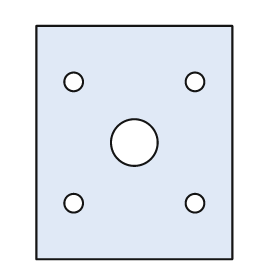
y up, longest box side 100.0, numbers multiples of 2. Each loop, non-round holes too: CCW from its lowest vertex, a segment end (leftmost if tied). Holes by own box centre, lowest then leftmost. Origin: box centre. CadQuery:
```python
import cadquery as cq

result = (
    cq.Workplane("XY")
    .moveTo(-42.0, -50.0)
    .lineTo(42.0, -50.0)
    .lineTo(42.0, 50.0)
    .lineTo(-42.0, 50.0)
    .close()
    .moveTo(-26.0, -26.0)
    .circle(4.0)
    .moveTo(26.0, -26.0)
    .circle(4.0)
    .moveTo(0.0, 0.0)
    .circle(10.0)
    .moveTo(-26.0, 26.0)
    .circle(4.0)
    .moveTo(26.0, 26.0)
    .circle(4.0)
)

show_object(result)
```